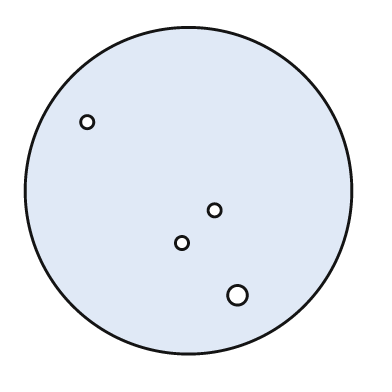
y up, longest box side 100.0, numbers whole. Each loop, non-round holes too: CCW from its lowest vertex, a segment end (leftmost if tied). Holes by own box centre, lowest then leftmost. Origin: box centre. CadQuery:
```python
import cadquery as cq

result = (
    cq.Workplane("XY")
    .moveTo(0.0, 0.0)
    .circle(50.0)
    .moveTo(15.0, -32.0)
    .circle(3.0)
    .moveTo(-2.0, -16.0)
    .circle(2.0)
    .moveTo(8.0, -6.0)
    .circle(2.0)
    .moveTo(-31.0, 21.0)
    .circle(2.0)
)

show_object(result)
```